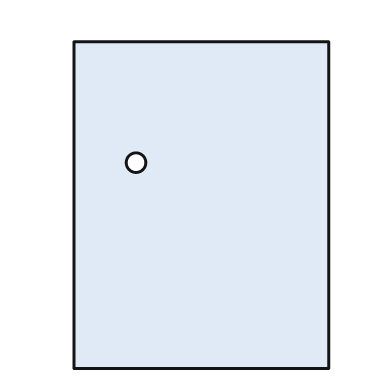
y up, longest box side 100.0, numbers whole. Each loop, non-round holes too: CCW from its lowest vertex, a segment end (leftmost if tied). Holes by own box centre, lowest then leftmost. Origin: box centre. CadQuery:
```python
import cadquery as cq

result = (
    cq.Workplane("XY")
    .moveTo(-39.0, -50.0)
    .lineTo(39.0, -50.0)
    .lineTo(39.0, 50.0)
    .lineTo(-39.0, 50.0)
    .close()
    .moveTo(-20.0, 13.0)
    .circle(3.0)
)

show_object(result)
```